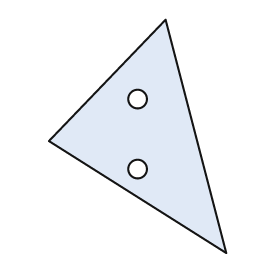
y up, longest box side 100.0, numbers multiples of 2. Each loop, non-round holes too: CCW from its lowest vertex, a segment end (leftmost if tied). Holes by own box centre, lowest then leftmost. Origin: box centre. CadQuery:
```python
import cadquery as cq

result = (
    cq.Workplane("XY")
    .moveTo(38.0, -50.0)
    .lineTo(12.0, 50.0)
    .lineTo(-38.0, -2.0)
    .close()
    .moveTo(0.0, -14.0)
    .circle(4.0)
    .moveTo(0.0, 16.0)
    .circle(4.0)
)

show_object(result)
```